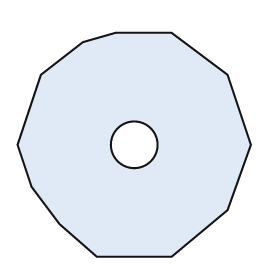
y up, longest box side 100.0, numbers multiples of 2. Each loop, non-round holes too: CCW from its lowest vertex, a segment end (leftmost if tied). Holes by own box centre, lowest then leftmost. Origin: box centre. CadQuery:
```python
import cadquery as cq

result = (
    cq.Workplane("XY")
    .moveTo(-16.0, -48.0)
    .lineTo(16.0, -48.0)
    .lineTo(40.0, -28.0)
    .lineTo(50.0, 0.0)
    .lineTo(40.0, 30.0)
    .lineTo(16.0, 48.0)
    .lineTo(-8.0, 48.0)
    .lineTo(-22.0, 44.0)
    .lineTo(-40.0, 30.0)
    .lineTo(-50.0, 0.0)
    .lineTo(-44.0, -18.0)
    .lineTo(-32.0, -34.0)
    .close()
    .moveTo(0.0, 0.0)
    .circle(10.0)
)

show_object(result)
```